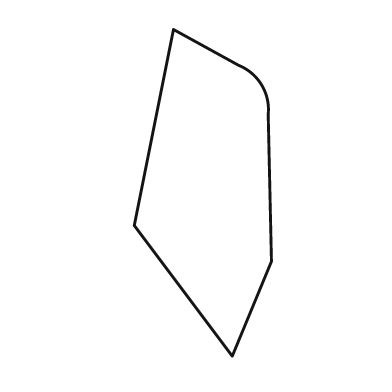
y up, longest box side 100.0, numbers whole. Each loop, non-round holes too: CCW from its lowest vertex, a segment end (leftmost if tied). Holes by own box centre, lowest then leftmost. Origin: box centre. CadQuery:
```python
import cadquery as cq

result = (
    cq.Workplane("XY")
    .moveTo(9.0, -50.0)
    .lineTo(21.0, -21.0)
    .lineTo(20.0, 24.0)
    .threePointArc((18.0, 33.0), (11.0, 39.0))
    .lineTo(-9.0, 50.0)
    .lineTo(-21.0, -10.0)
    .close()
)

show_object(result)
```